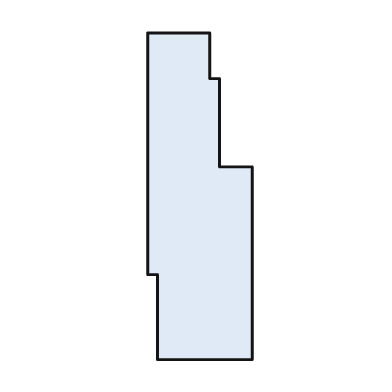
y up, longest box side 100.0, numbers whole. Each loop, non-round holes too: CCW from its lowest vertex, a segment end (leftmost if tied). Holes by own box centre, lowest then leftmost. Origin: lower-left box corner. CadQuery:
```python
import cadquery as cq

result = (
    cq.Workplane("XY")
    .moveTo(3.0, 0.0)
    .lineTo(32.0, 0.0)
    .lineTo(32.0, 59.0)
    .lineTo(22.0, 59.0)
    .lineTo(22.0, 86.0)
    .lineTo(19.0, 86.0)
    .lineTo(19.0, 100.0)
    .lineTo(0.0, 100.0)
    .lineTo(0.0, 26.0)
    .lineTo(3.0, 26.0)
    .close()
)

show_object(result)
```